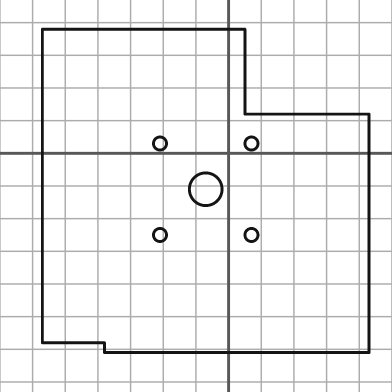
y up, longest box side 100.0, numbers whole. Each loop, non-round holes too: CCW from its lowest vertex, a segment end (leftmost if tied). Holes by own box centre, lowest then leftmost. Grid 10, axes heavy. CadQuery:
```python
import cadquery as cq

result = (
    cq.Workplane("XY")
    .moveTo(-38.0, -61.0)
    .lineTo(43.0, -61.0)
    .lineTo(43.0, 12.0)
    .lineTo(5.0, 12.0)
    .lineTo(5.0, 38.0)
    .lineTo(-57.0, 38.0)
    .lineTo(-57.0, -58.0)
    .lineTo(-38.0, -58.0)
    .close()
    .moveTo(-21.0, -25.0)
    .circle(2.0)
    .moveTo(7.0, -25.0)
    .circle(2.0)
    .moveTo(-7.0, -11.0)
    .circle(5.0)
    .moveTo(-21.0, 3.0)
    .circle(2.0)
    .moveTo(7.0, 3.0)
    .circle(2.0)
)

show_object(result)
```